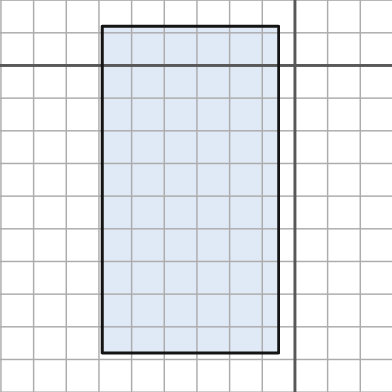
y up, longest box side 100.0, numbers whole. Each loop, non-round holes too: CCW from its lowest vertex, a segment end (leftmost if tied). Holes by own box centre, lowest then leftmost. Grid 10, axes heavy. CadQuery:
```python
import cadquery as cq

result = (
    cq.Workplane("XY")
    .moveTo(-59.0, -88.0)
    .lineTo(-5.0, -88.0)
    .lineTo(-5.0, 12.0)
    .lineTo(-59.0, 12.0)
    .close()
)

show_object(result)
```